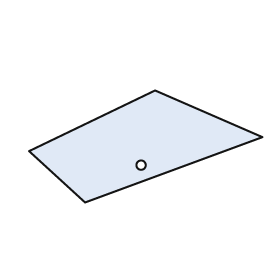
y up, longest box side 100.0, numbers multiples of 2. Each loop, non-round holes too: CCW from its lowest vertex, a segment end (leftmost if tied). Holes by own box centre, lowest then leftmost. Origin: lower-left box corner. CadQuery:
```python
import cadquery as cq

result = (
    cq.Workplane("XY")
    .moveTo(24.0, 0.0)
    .lineTo(100.0, 28.0)
    .lineTo(54.0, 48.0)
    .lineTo(0.0, 22.0)
    .close()
    .moveTo(48.0, 16.0)
    .circle(2.0)
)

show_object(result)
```